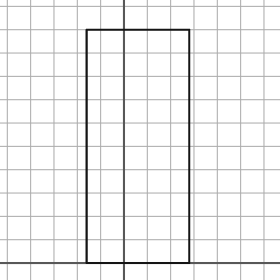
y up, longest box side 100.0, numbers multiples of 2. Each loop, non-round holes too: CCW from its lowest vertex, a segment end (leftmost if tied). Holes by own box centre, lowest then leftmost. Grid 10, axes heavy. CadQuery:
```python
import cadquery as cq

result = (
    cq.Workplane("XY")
    .moveTo(-16.0, 0.0)
    .lineTo(28.0, 0.0)
    .lineTo(28.0, 100.0)
    .lineTo(-16.0, 100.0)
    .close()
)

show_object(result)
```